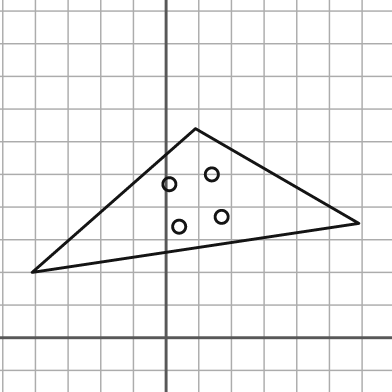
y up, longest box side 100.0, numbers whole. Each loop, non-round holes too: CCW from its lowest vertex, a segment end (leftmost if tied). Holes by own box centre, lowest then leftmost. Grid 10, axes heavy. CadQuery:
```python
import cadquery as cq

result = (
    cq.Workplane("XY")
    .moveTo(-41.0, 20.0)
    .lineTo(59.0, 35.0)
    .lineTo(9.0, 64.0)
    .close()
    .moveTo(4.0, 34.0)
    .circle(2.0)
    .moveTo(17.0, 37.0)
    .circle(2.0)
    .moveTo(1.0, 47.0)
    .circle(2.0)
    .moveTo(14.0, 50.0)
    .circle(2.0)
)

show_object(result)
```